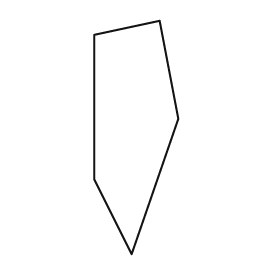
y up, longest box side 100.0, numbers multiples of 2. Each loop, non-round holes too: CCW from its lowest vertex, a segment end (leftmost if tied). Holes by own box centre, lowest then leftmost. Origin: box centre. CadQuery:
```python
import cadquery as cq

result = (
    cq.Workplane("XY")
    .moveTo(-2.0, -50.0)
    .lineTo(18.0, 8.0)
    .lineTo(10.0, 50.0)
    .lineTo(-18.0, 44.0)
    .lineTo(-18.0, -18.0)
    .close()
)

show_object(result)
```